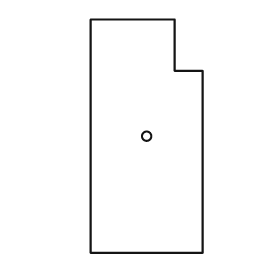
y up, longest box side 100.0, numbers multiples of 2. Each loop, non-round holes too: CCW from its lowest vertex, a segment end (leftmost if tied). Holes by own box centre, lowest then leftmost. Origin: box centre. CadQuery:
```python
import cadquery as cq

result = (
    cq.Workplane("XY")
    .moveTo(-24.0, -50.0)
    .lineTo(24.0, -50.0)
    .lineTo(24.0, 28.0)
    .lineTo(12.0, 28.0)
    .lineTo(12.0, 50.0)
    .lineTo(-24.0, 50.0)
    .close()
    .moveTo(0.0, 0.0)
    .circle(2.0)
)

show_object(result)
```